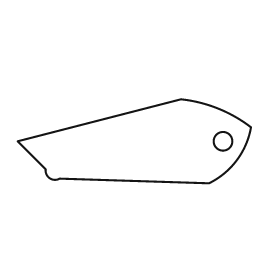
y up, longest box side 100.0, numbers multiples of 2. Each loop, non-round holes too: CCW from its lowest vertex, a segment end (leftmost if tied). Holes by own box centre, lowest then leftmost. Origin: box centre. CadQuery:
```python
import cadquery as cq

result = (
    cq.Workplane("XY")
    .moveTo(32.0, -18.0)
    .threePointArc((44.0, -8.0), (50.0, 6.0))
    .threePointArc((36.0, 14.0), (20.0, 18.0))
    .lineTo(-50.0, 0.0)
    .lineTo(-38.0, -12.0)
    .threePointArc((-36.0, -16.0), (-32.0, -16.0))
    .close()
    .moveTo(38.0, 0.0)
    .circle(4.0)
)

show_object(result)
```